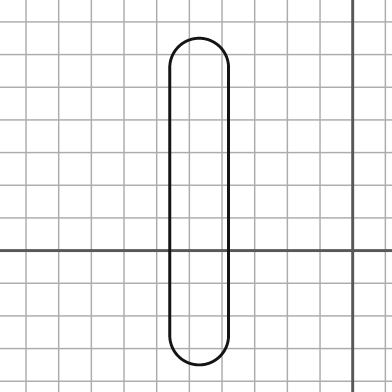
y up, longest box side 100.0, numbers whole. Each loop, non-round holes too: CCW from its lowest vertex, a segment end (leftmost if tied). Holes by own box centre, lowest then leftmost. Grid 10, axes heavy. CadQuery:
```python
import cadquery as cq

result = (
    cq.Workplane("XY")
    .moveTo(-56.0, -26.0)
    .threePointArc((-47.0, -35.0), (-38.0, -26.0))
    .lineTo(-38.0, 56.0)
    .threePointArc((-47.0, 65.0), (-56.0, 56.0))
    .close()
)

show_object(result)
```